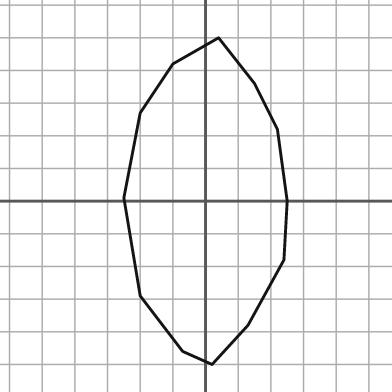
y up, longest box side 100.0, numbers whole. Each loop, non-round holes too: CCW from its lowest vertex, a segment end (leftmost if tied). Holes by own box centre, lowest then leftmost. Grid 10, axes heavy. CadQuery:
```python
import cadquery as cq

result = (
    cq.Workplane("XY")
    .moveTo(2.0, -50.0)
    .lineTo(13.0, -38.0)
    .lineTo(24.0, -18.0)
    .lineTo(25.0, 0.0)
    .lineTo(22.0, 22.0)
    .lineTo(15.0, 36.0)
    .lineTo(4.0, 50.0)
    .lineTo(-10.0, 42.0)
    .lineTo(-20.0, 27.0)
    .lineTo(-25.0, 1.0)
    .lineTo(-20.0, -29.0)
    .lineTo(-7.0, -46.0)
    .close()
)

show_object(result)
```